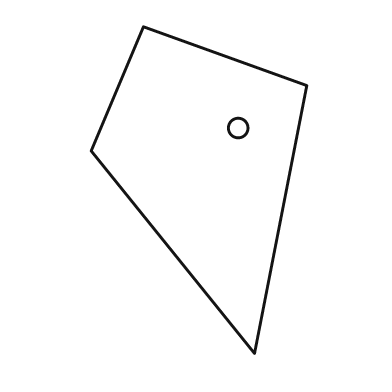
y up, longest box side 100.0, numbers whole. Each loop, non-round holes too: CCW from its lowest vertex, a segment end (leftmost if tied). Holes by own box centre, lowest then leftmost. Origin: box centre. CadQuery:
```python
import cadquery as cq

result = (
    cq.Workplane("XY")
    .moveTo(17.0, -50.0)
    .lineTo(33.0, 32.0)
    .lineTo(-17.0, 50.0)
    .lineTo(-33.0, 12.0)
    .close()
    .moveTo(12.0, 19.0)
    .circle(3.0)
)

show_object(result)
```